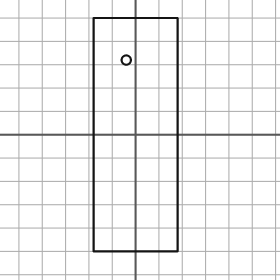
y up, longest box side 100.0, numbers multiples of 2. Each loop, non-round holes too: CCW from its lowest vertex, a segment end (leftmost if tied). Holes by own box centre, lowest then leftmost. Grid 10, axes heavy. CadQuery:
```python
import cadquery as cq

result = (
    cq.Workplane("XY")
    .moveTo(-18.0, -50.0)
    .lineTo(18.0, -50.0)
    .lineTo(18.0, 50.0)
    .lineTo(-18.0, 50.0)
    .close()
    .moveTo(-4.0, 32.0)
    .circle(2.0)
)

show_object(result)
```